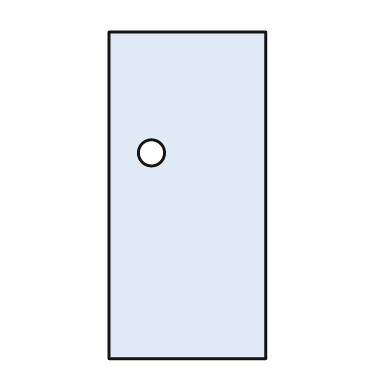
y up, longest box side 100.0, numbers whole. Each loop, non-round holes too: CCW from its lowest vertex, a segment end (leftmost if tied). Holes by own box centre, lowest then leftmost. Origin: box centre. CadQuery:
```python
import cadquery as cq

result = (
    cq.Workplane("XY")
    .moveTo(-24.0, -50.0)
    .lineTo(24.0, -50.0)
    .lineTo(24.0, 50.0)
    .lineTo(-24.0, 50.0)
    .close()
    .moveTo(-11.0, 13.0)
    .circle(4.0)
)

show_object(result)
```